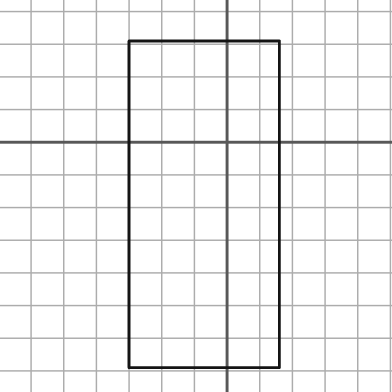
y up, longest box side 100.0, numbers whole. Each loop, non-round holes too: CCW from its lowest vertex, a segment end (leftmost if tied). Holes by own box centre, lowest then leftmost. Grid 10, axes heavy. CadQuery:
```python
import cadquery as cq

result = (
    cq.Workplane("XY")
    .moveTo(-30.0, -69.0)
    .lineTo(16.0, -69.0)
    .lineTo(16.0, 31.0)
    .lineTo(-30.0, 31.0)
    .close()
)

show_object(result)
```